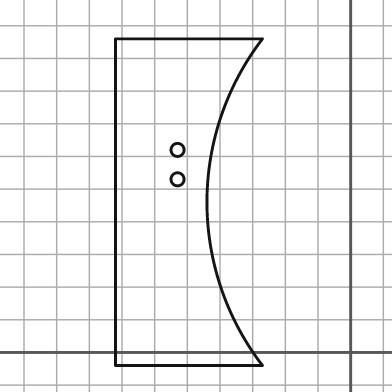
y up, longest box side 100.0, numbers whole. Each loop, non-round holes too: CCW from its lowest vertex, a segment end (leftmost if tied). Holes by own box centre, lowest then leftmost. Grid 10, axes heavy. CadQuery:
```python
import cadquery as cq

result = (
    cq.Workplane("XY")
    .moveTo(-72.0, -4.0)
    .lineTo(-27.0, -4.0)
    .threePointArc((-44.0, 46.0), (-27.0, 96.0))
    .lineTo(-72.0, 96.0)
    .close()
    .moveTo(-53.0, 53.0)
    .circle(2.0)
    .moveTo(-53.0, 62.0)
    .circle(2.0)
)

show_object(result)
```